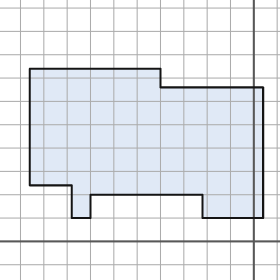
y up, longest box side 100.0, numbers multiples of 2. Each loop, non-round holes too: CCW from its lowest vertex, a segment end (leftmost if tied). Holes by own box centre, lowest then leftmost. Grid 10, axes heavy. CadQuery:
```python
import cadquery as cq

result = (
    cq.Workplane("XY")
    .moveTo(-78.0, 10.0)
    .lineTo(-70.0, 10.0)
    .lineTo(-70.0, 20.0)
    .lineTo(-22.0, 20.0)
    .lineTo(-22.0, 10.0)
    .lineTo(4.0, 10.0)
    .lineTo(4.0, 66.0)
    .lineTo(-40.0, 66.0)
    .lineTo(-40.0, 74.0)
    .lineTo(-96.0, 74.0)
    .lineTo(-96.0, 24.0)
    .lineTo(-78.0, 24.0)
    .close()
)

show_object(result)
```